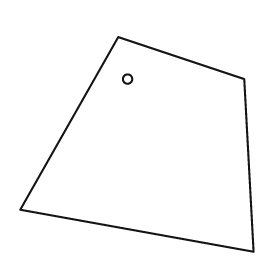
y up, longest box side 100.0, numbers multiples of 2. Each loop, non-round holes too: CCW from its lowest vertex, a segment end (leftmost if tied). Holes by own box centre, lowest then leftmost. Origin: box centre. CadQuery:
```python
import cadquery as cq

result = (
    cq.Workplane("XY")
    .moveTo(50.0, -46.0)
    .lineTo(46.0, 28.0)
    .lineTo(-8.0, 46.0)
    .lineTo(-50.0, -28.0)
    .close()
    .moveTo(-4.0, 28.0)
    .circle(2.0)
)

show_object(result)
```